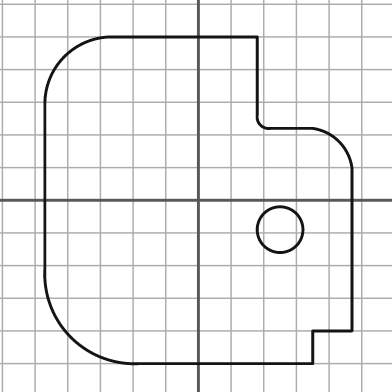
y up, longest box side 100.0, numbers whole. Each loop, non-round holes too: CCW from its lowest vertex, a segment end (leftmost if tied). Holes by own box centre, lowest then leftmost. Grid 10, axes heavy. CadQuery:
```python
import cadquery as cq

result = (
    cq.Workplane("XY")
    .moveTo(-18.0, -50.0)
    .lineTo(35.0, -50.0)
    .lineTo(35.0, -40.0)
    .lineTo(47.0, -40.0)
    .lineTo(47.0, 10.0)
    .threePointArc((43.0, 18.0), (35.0, 22.0))
    .lineTo(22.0, 22.0)
    .threePointArc((19.0, 23.0), (18.0, 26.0))
    .lineTo(18.0, 50.0)
    .lineTo(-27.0, 50.0)
    .threePointArc((-41.0, 44.0), (-47.0, 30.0))
    .lineTo(-47.0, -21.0)
    .threePointArc((-39.0, -42.0), (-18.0, -50.0))
    .close()
    .moveTo(25.0, -9.0)
    .circle(7.0)
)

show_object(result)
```